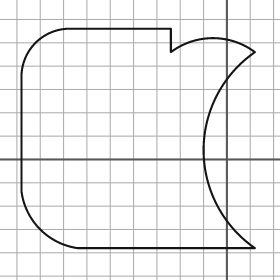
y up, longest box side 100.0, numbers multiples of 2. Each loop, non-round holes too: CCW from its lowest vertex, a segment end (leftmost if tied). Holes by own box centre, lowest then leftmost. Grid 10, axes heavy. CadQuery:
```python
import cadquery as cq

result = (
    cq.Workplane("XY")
    .moveTo(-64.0, -38.0)
    .lineTo(12.0, -38.0)
    .threePointArc((-10.0, 4.0), (12.0, 46.0))
    .threePointArc((-6.0, 52.0), (-24.0, 46.0))
    .lineTo(-24.0, 56.0)
    .lineTo(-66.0, 56.0)
    .threePointArc((-82.0, 50.0), (-88.0, 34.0))
    .lineTo(-88.0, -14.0)
    .threePointArc((-80.0, -30.0), (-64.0, -38.0))
    .close()
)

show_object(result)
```